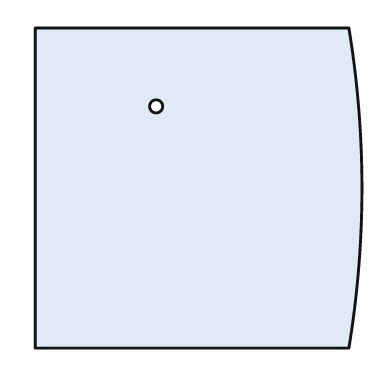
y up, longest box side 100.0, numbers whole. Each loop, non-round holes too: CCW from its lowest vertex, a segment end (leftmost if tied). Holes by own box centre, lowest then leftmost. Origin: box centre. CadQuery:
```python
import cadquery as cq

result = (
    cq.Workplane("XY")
    .moveTo(-50.0, -49.0)
    .lineTo(46.0, -49.0)
    .threePointArc((50.0, 0.0), (46.0, 49.0))
    .lineTo(-50.0, 49.0)
    .close()
    .moveTo(-13.0, 25.0)
    .circle(2.0)
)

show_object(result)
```